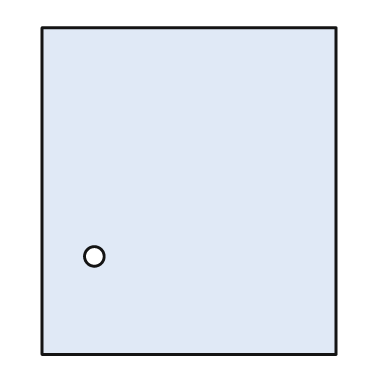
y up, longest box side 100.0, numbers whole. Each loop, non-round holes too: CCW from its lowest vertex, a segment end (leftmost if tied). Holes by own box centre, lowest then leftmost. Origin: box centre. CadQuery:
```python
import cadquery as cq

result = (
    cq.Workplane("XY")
    .moveTo(-45.0, -50.0)
    .lineTo(45.0, -50.0)
    .lineTo(45.0, 50.0)
    .lineTo(-45.0, 50.0)
    .close()
    .moveTo(-29.0, -20.0)
    .circle(3.0)
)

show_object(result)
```